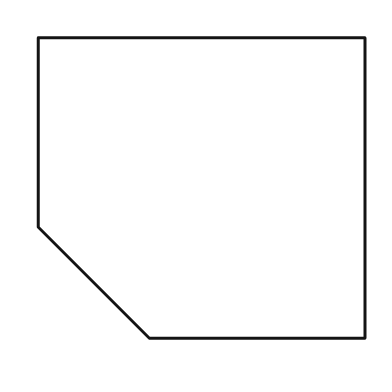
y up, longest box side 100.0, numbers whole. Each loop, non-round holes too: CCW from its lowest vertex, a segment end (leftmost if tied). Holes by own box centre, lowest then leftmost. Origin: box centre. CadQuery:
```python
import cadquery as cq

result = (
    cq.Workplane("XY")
    .moveTo(-16.0, -46.0)
    .lineTo(50.0, -46.0)
    .lineTo(50.0, 46.0)
    .lineTo(-50.0, 46.0)
    .lineTo(-50.0, -12.0)
    .close()
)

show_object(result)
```